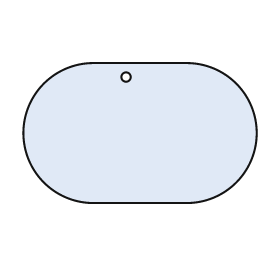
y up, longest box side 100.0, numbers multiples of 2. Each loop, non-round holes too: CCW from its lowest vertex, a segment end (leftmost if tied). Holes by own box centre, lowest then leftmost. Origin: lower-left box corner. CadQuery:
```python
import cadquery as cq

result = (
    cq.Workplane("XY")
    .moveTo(30.0, 0.0)
    .lineTo(70.0, 0.0)
    .threePointArc((100.0, 30.0), (70.0, 60.0))
    .lineTo(30.0, 60.0)
    .threePointArc((0.0, 30.0), (30.0, 0.0))
    .close()
    .moveTo(44.0, 54.0)
    .circle(2.0)
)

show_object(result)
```